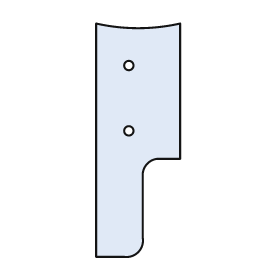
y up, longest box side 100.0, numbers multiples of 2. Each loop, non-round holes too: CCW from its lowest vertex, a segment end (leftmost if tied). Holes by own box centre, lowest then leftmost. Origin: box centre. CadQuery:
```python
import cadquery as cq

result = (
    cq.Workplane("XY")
    .moveTo(-18.0, -50.0)
    .lineTo(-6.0, -50.0)
    .threePointArc((0.0, -48.0), (2.0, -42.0))
    .lineTo(2.0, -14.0)
    .threePointArc((4.0, -10.0), (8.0, -8.0))
    .lineTo(18.0, -8.0)
    .lineTo(18.0, 50.0)
    .threePointArc((0.0, 48.0), (-18.0, 50.0))
    .close()
    .moveTo(-4.0, 4.0)
    .circle(2.0)
    .moveTo(-4.0, 32.0)
    .circle(2.0)
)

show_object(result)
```